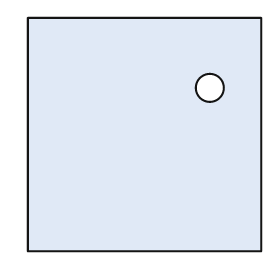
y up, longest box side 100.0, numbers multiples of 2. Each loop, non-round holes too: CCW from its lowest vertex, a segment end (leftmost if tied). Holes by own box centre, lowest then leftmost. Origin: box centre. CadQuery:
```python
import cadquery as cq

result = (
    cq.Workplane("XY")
    .moveTo(-50.0, -50.0)
    .lineTo(50.0, -50.0)
    .lineTo(50.0, 50.0)
    .lineTo(-50.0, 50.0)
    .close()
    .moveTo(28.0, 20.0)
    .circle(6.0)
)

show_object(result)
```